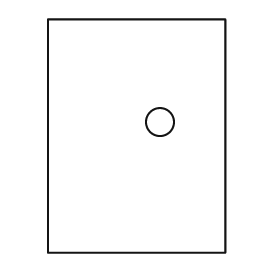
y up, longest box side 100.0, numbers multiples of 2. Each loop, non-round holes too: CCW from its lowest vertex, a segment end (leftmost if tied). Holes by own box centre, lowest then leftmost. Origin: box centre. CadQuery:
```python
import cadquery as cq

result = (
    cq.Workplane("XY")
    .moveTo(-38.0, -50.0)
    .lineTo(38.0, -50.0)
    .lineTo(38.0, 50.0)
    .lineTo(-38.0, 50.0)
    .close()
    .moveTo(10.0, 6.0)
    .circle(6.0)
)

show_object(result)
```